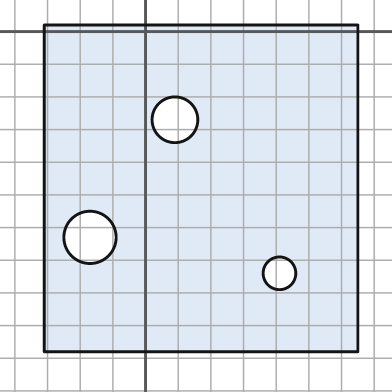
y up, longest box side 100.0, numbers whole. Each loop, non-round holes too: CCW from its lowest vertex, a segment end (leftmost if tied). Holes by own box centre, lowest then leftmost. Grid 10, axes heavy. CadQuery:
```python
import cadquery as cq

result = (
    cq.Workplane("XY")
    .moveTo(-31.0, -98.0)
    .lineTo(65.0, -98.0)
    .lineTo(65.0, 2.0)
    .lineTo(-31.0, 2.0)
    .close()
    .moveTo(41.0, -74.0)
    .circle(5.0)
    .moveTo(-17.0, -63.0)
    .circle(8.0)
    .moveTo(9.0, -27.0)
    .circle(7.0)
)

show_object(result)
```